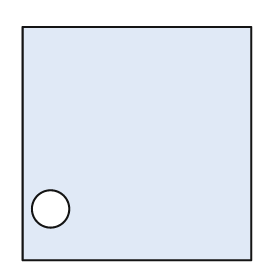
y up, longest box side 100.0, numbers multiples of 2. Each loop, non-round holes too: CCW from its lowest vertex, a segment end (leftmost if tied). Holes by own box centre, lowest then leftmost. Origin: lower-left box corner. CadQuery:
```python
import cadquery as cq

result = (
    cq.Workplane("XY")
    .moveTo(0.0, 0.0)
    .lineTo(98.0, 0.0)
    .lineTo(98.0, 100.0)
    .lineTo(0.0, 100.0)
    .close()
    .moveTo(12.0, 22.0)
    .circle(8.0)
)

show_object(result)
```